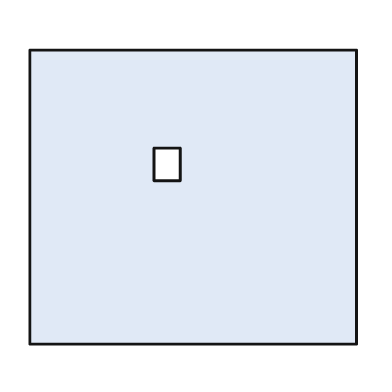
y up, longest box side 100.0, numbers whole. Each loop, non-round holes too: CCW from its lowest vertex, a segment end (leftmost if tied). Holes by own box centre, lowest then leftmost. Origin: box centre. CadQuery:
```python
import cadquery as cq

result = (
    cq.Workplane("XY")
    .moveTo(-50.0, -45.0)
    .lineTo(50.0, -45.0)
    .lineTo(50.0, 45.0)
    .lineTo(-50.0, 45.0)
    .close()
    .moveTo(-12.0, 5.0)
    .lineTo(-4.0, 5.0)
    .lineTo(-4.0, 15.0)
    .lineTo(-12.0, 15.0)
    .close()
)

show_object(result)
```